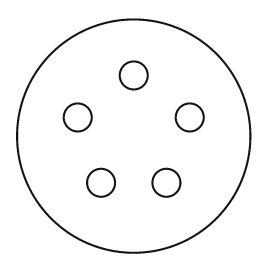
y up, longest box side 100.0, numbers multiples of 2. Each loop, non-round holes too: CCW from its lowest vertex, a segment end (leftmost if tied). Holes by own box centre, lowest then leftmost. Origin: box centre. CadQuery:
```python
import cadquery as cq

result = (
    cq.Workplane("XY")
    .moveTo(0.0, 0.0)
    .circle(50.0)
    .moveTo(-14.0, -20.0)
    .circle(6.0)
    .moveTo(14.0, -20.0)
    .circle(6.0)
    .moveTo(-24.0, 8.0)
    .circle(6.0)
    .moveTo(24.0, 8.0)
    .circle(6.0)
    .moveTo(0.0, 26.0)
    .circle(6.0)
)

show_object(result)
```